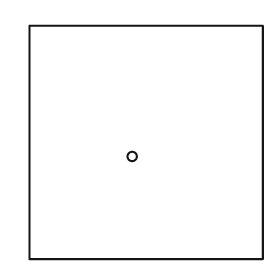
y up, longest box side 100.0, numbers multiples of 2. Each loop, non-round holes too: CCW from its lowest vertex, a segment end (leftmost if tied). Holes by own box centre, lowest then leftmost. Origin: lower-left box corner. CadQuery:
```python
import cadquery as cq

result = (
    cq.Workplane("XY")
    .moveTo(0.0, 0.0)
    .lineTo(100.0, 0.0)
    .lineTo(100.0, 100.0)
    .lineTo(0.0, 100.0)
    .close()
    .moveTo(44.0, 44.0)
    .circle(2.0)
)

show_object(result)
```